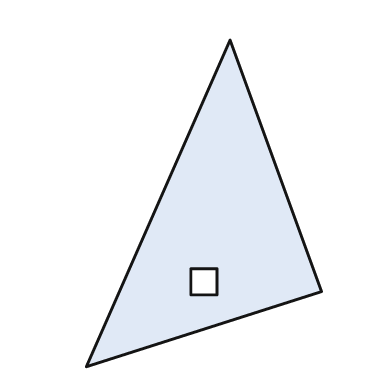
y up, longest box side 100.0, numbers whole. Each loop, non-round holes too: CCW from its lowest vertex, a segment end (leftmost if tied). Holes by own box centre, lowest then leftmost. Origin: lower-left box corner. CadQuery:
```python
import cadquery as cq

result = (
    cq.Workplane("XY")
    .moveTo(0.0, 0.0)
    .lineTo(72.0, 23.0)
    .lineTo(44.0, 100.0)
    .close()
    .moveTo(32.0, 22.0)
    .lineTo(40.0, 22.0)
    .lineTo(40.0, 30.0)
    .lineTo(32.0, 30.0)
    .close()
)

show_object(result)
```